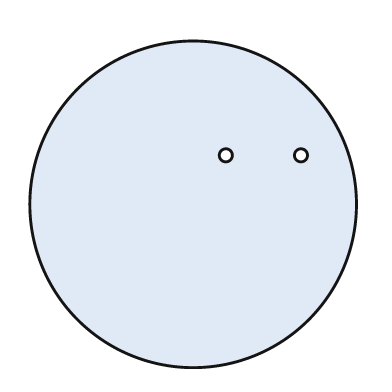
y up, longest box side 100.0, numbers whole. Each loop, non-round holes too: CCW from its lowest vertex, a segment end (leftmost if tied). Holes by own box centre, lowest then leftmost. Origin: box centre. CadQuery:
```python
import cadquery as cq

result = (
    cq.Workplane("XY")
    .moveTo(0.0, 0.0)
    .circle(50.0)
    .moveTo(10.0, 15.0)
    .circle(2.0)
    .moveTo(33.0, 15.0)
    .circle(2.0)
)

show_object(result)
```